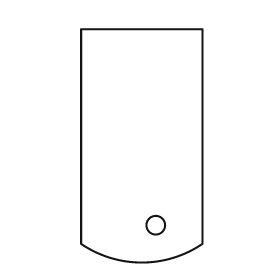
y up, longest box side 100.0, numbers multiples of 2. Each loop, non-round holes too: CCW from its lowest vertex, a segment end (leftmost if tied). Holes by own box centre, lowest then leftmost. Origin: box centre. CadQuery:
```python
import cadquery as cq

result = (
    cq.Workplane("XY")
    .moveTo(-26.0, -42.0)
    .threePointArc((0.0, -50.0), (26.0, -42.0))
    .lineTo(26.0, 50.0)
    .lineTo(-26.0, 50.0)
    .close()
    .moveTo(6.0, -34.0)
    .circle(4.0)
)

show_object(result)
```